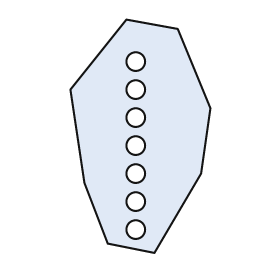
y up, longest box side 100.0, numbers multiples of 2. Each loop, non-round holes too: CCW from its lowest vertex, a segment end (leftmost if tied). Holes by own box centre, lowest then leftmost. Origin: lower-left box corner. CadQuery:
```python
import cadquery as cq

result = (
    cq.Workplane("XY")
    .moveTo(36.0, 0.0)
    .lineTo(56.0, 34.0)
    .lineTo(60.0, 62.0)
    .lineTo(46.0, 96.0)
    .lineTo(24.0, 100.0)
    .lineTo(0.0, 70.0)
    .lineTo(6.0, 30.0)
    .lineTo(16.0, 4.0)
    .close()
    .moveTo(28.0, 10.0)
    .circle(4.0)
    .moveTo(28.0, 22.0)
    .circle(4.0)
    .moveTo(28.0, 34.0)
    .circle(4.0)
    .moveTo(28.0, 46.0)
    .circle(4.0)
    .moveTo(28.0, 58.0)
    .circle(4.0)
    .moveTo(28.0, 70.0)
    .circle(4.0)
    .moveTo(28.0, 82.0)
    .circle(4.0)
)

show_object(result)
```